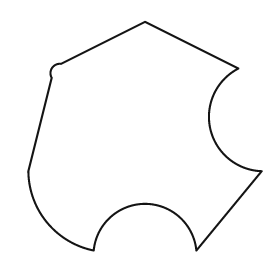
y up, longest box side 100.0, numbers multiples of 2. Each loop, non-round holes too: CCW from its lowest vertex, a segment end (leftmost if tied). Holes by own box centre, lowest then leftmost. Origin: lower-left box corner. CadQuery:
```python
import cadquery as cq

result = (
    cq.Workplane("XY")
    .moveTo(28.0, 0.0)
    .threePointArc((50.0, 20.0), (72.0, 0.0))
    .lineTo(100.0, 34.0)
    .threePointArc((78.0, 52.0), (90.0, 78.0))
    .lineTo(50.0, 98.0)
    .lineTo(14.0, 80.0)
    .threePointArc((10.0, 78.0), (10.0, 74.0))
    .lineTo(0.0, 34.0)
    .threePointArc((8.0, 12.0), (28.0, 0.0))
    .close()
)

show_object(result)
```